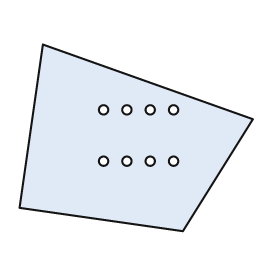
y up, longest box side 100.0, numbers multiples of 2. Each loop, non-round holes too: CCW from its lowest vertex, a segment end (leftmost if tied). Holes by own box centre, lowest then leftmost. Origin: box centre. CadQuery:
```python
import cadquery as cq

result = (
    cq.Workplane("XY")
    .moveTo(20.0, -40.0)
    .lineTo(50.0, 8.0)
    .lineTo(-40.0, 40.0)
    .lineTo(-50.0, -30.0)
    .close()
    .moveTo(-14.0, -10.0)
    .circle(2.0)
    .moveTo(-4.0, -10.0)
    .circle(2.0)
    .moveTo(6.0, -10.0)
    .circle(2.0)
    .moveTo(16.0, -10.0)
    .circle(2.0)
    .moveTo(-14.0, 12.0)
    .circle(2.0)
    .moveTo(-4.0, 12.0)
    .circle(2.0)
    .moveTo(6.0, 12.0)
    .circle(2.0)
    .moveTo(16.0, 12.0)
    .circle(2.0)
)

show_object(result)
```